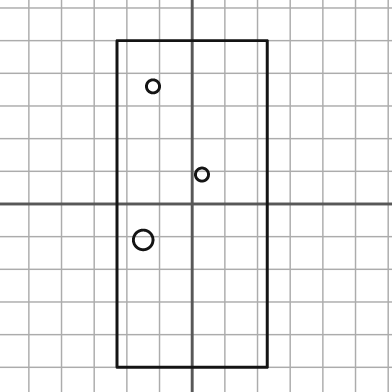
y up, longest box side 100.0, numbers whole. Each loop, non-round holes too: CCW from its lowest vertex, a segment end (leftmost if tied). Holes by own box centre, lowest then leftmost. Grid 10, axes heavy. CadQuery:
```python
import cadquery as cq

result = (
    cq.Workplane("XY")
    .moveTo(-23.0, -50.0)
    .lineTo(23.0, -50.0)
    .lineTo(23.0, 50.0)
    .lineTo(-23.0, 50.0)
    .close()
    .moveTo(-15.0, -11.0)
    .circle(3.0)
    .moveTo(3.0, 9.0)
    .circle(2.0)
    .moveTo(-12.0, 36.0)
    .circle(2.0)
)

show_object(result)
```